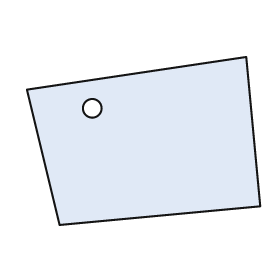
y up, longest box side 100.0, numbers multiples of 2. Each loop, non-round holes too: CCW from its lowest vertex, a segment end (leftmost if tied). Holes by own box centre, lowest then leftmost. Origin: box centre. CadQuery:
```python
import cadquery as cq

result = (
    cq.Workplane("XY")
    .moveTo(-36.0, -36.0)
    .lineTo(50.0, -28.0)
    .lineTo(44.0, 36.0)
    .lineTo(-50.0, 22.0)
    .close()
    .moveTo(-22.0, 14.0)
    .circle(4.0)
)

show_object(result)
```